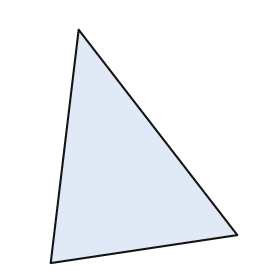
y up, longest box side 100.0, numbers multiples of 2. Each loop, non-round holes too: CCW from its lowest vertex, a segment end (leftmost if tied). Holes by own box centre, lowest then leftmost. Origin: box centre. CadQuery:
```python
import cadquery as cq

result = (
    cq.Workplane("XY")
    .moveTo(-40.0, -50.0)
    .lineTo(40.0, -38.0)
    .lineTo(-28.0, 50.0)
    .close()
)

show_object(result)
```